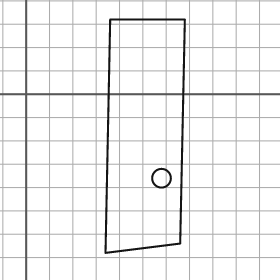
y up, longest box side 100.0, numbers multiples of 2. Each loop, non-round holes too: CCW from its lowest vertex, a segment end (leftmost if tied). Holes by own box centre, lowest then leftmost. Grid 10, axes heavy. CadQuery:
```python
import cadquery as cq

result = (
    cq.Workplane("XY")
    .moveTo(34.0, -68.0)
    .lineTo(66.0, -64.0)
    .lineTo(68.0, 32.0)
    .lineTo(36.0, 32.0)
    .close()
    .moveTo(58.0, -36.0)
    .circle(4.0)
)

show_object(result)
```